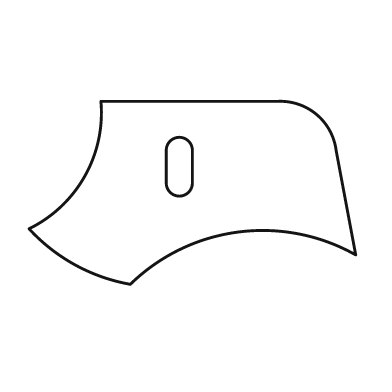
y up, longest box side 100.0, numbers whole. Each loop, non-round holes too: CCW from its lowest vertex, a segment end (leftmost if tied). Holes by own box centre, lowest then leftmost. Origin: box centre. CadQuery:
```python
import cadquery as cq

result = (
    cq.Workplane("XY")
    .moveTo(-19.0, -28.0)
    .threePointArc((14.0, -12.0), (50.0, -19.0))
    .lineTo(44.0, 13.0)
    .threePointArc((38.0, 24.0), (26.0, 28.0))
    .lineTo(-28.0, 28.0)
    .threePointArc((-33.0, 5.0), (-50.0, -11.0))
    .threePointArc((-36.0, -22.0), (-19.0, -28.0))
    .close()
    .moveTo(-8.0, 3.0)
    .threePointArc((-4.0, -1.0), (0.0, 3.0))
    .lineTo(0.0, 13.0)
    .threePointArc((-4.0, 17.0), (-8.0, 13.0))
    .close()
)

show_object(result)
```